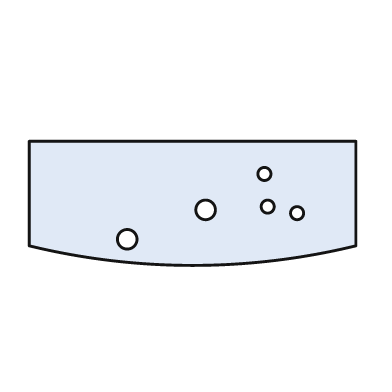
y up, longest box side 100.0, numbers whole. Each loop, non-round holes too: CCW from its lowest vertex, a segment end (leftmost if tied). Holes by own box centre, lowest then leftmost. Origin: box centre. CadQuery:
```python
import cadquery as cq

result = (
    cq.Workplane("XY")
    .moveTo(-50.0, -13.0)
    .threePointArc((0.0, -19.0), (50.0, -13.0))
    .lineTo(50.0, 19.0)
    .lineTo(-50.0, 19.0)
    .close()
    .moveTo(-20.0, -11.0)
    .circle(3.0)
    .moveTo(32.0, -3.0)
    .circle(2.0)
    .moveTo(4.0, -2.0)
    .circle(3.0)
    .moveTo(23.0, -1.0)
    .circle(2.0)
    .moveTo(22.0, 9.0)
    .circle(2.0)
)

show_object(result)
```